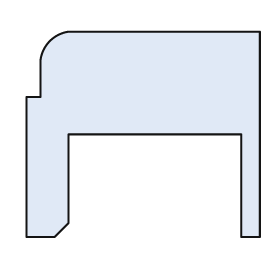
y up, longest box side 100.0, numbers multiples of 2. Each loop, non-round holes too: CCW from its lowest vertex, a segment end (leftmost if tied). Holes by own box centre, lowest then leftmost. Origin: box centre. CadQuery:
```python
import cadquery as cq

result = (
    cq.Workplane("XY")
    .moveTo(-50.0, -44.0)
    .lineTo(-38.0, -44.0)
    .lineTo(-32.0, -38.0)
    .lineTo(-32.0, 0.0)
    .lineTo(42.0, 0.0)
    .lineTo(42.0, -44.0)
    .lineTo(50.0, -44.0)
    .lineTo(50.0, 44.0)
    .lineTo(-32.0, 44.0)
    .threePointArc((-40.0, 40.0), (-44.0, 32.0))
    .lineTo(-44.0, 16.0)
    .lineTo(-50.0, 16.0)
    .close()
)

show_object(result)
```